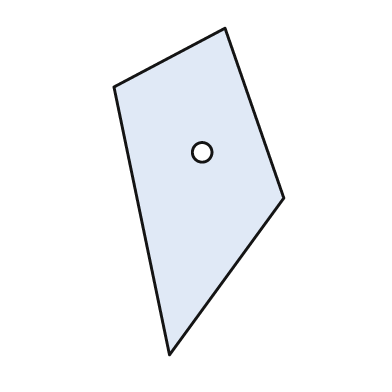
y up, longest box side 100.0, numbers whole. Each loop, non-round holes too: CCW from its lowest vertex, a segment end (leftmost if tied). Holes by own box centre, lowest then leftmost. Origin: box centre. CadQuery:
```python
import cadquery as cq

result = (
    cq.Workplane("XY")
    .moveTo(-9.0, -50.0)
    .lineTo(26.0, -2.0)
    .lineTo(8.0, 50.0)
    .lineTo(-26.0, 32.0)
    .close()
    .moveTo(1.0, 12.0)
    .circle(3.0)
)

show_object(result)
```